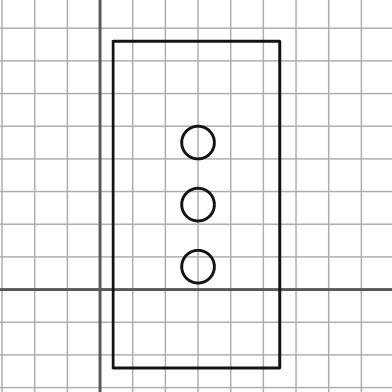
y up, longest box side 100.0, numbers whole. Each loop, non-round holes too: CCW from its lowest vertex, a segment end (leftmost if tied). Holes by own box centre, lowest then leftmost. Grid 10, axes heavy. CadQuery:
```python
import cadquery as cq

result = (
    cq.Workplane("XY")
    .moveTo(4.0, -24.0)
    .lineTo(55.0, -24.0)
    .lineTo(55.0, 76.0)
    .lineTo(4.0, 76.0)
    .close()
    .moveTo(30.0, 7.0)
    .circle(5.0)
    .moveTo(30.0, 26.0)
    .circle(5.0)
    .moveTo(30.0, 45.0)
    .circle(5.0)
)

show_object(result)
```